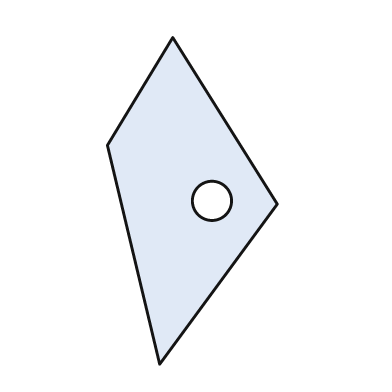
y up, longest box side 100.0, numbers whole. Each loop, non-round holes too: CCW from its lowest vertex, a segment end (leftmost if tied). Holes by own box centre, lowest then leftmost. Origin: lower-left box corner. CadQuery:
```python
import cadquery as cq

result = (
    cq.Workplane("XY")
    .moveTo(16.0, 0.0)
    .lineTo(52.0, 49.0)
    .lineTo(20.0, 100.0)
    .lineTo(0.0, 67.0)
    .close()
    .moveTo(32.0, 50.0)
    .circle(6.0)
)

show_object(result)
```